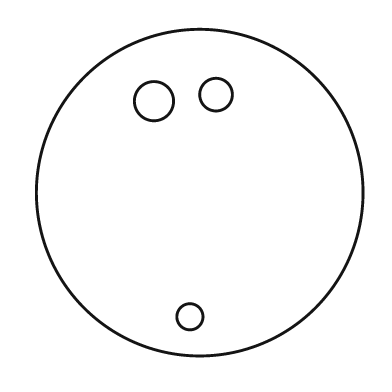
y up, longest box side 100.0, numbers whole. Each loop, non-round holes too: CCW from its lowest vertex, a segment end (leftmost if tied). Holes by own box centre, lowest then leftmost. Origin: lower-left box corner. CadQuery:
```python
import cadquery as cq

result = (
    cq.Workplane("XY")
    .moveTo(50.0, 50.0)
    .circle(50.0)
    .moveTo(47.0, 12.0)
    .circle(4.0)
    .moveTo(36.0, 78.0)
    .circle(6.0)
    .moveTo(55.0, 80.0)
    .circle(5.0)
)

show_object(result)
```